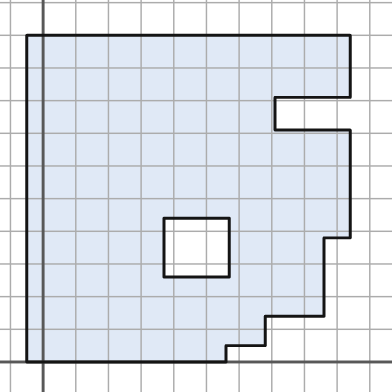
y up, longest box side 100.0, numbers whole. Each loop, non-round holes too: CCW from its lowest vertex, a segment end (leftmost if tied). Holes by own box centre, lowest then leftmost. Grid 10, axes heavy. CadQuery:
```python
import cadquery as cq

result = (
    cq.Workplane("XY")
    .moveTo(-5.0, 0.0)
    .lineTo(56.0, 0.0)
    .lineTo(56.0, 5.0)
    .lineTo(68.0, 5.0)
    .lineTo(68.0, 14.0)
    .lineTo(86.0, 14.0)
    .lineTo(86.0, 38.0)
    .lineTo(94.0, 38.0)
    .lineTo(94.0, 71.0)
    .lineTo(71.0, 71.0)
    .lineTo(71.0, 81.0)
    .lineTo(94.0, 81.0)
    .lineTo(94.0, 100.0)
    .lineTo(-5.0, 100.0)
    .close()
    .moveTo(37.0, 26.0)
    .lineTo(57.0, 26.0)
    .lineTo(57.0, 44.0)
    .lineTo(37.0, 44.0)
    .close()
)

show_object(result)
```